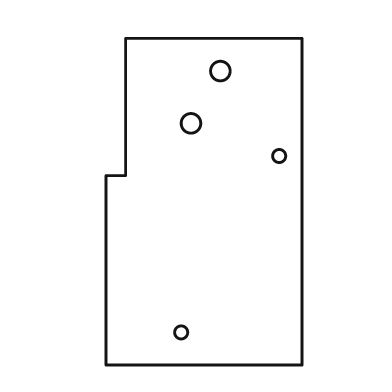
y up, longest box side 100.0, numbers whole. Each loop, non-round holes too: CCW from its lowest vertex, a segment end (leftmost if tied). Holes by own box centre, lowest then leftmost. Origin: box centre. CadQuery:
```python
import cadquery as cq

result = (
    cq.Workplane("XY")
    .moveTo(-30.0, -50.0)
    .lineTo(30.0, -50.0)
    .lineTo(30.0, 50.0)
    .lineTo(-24.0, 50.0)
    .lineTo(-24.0, 8.0)
    .lineTo(-30.0, 8.0)
    .close()
    .moveTo(-7.0, -40.0)
    .circle(2.0)
    .moveTo(23.0, 14.0)
    .circle(2.0)
    .moveTo(-4.0, 24.0)
    .circle(3.0)
    .moveTo(5.0, 40.0)
    .circle(3.0)
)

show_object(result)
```